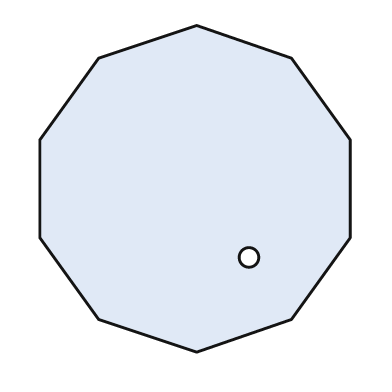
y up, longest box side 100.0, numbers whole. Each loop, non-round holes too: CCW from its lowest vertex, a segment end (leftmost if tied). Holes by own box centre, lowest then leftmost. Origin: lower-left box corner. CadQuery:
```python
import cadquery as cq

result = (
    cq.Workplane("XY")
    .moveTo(48.0, 0.0)
    .lineTo(77.0, 10.0)
    .lineTo(95.0, 35.0)
    .lineTo(95.0, 65.0)
    .lineTo(77.0, 90.0)
    .lineTo(48.0, 100.0)
    .lineTo(18.0, 90.0)
    .lineTo(0.0, 65.0)
    .lineTo(0.0, 35.0)
    .lineTo(18.0, 10.0)
    .close()
    .moveTo(64.0, 29.0)
    .circle(3.0)
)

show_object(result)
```